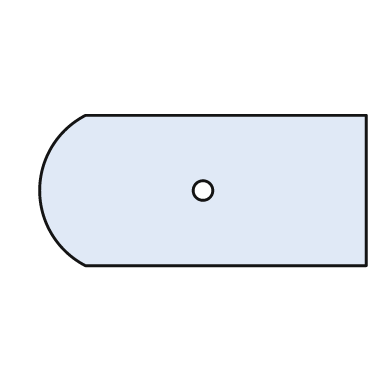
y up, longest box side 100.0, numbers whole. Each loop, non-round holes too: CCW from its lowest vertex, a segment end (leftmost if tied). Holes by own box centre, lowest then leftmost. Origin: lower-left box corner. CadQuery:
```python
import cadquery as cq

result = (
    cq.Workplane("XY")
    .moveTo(14.0, 0.0)
    .lineTo(100.0, 0.0)
    .lineTo(100.0, 46.0)
    .lineTo(14.0, 46.0)
    .threePointArc((0.0, 23.0), (14.0, 0.0))
    .close()
    .moveTo(50.0, 23.0)
    .circle(3.0)
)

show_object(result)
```